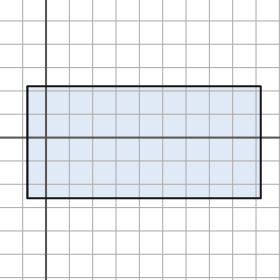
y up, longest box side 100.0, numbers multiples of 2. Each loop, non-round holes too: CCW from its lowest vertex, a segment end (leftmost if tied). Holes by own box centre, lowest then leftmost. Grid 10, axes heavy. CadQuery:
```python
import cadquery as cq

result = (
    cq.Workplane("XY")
    .moveTo(-8.0, -26.0)
    .lineTo(92.0, -26.0)
    .lineTo(92.0, 22.0)
    .lineTo(-8.0, 22.0)
    .close()
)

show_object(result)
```